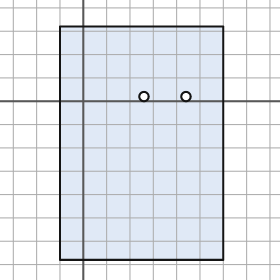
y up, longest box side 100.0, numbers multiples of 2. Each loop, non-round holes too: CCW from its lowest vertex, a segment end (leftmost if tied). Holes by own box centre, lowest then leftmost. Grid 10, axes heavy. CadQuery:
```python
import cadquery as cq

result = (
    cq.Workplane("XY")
    .moveTo(-10.0, -68.0)
    .lineTo(60.0, -68.0)
    .lineTo(60.0, 32.0)
    .lineTo(-10.0, 32.0)
    .close()
    .moveTo(26.0, 2.0)
    .circle(2.0)
    .moveTo(44.0, 2.0)
    .circle(2.0)
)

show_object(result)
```